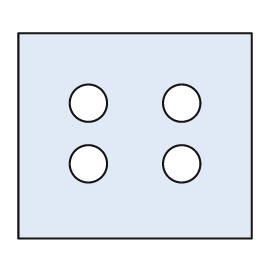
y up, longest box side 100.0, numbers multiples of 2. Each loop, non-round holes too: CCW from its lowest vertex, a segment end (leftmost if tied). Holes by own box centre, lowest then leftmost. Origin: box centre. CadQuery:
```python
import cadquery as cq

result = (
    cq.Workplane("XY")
    .moveTo(-50.0, -44.0)
    .lineTo(50.0, -44.0)
    .lineTo(50.0, 44.0)
    .lineTo(-50.0, 44.0)
    .close()
    .moveTo(-20.0, -12.0)
    .circle(8.0)
    .moveTo(20.0, -12.0)
    .circle(8.0)
    .moveTo(-20.0, 14.0)
    .circle(8.0)
    .moveTo(20.0, 14.0)
    .circle(8.0)
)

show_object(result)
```